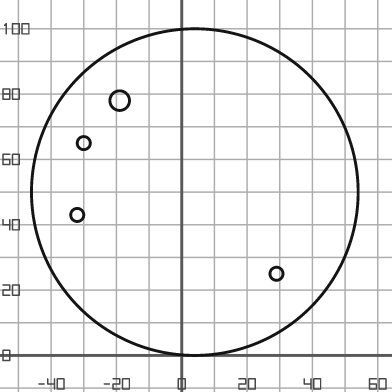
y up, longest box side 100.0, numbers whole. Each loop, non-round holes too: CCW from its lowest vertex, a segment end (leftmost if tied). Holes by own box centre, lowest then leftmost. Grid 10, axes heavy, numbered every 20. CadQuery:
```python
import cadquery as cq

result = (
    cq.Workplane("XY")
    .moveTo(4.0, 50.0)
    .circle(50.0)
    .moveTo(29.0, 25.0)
    .circle(2.0)
    .moveTo(-32.0, 43.0)
    .circle(2.0)
    .moveTo(-30.0, 65.0)
    .circle(2.0)
    .moveTo(-19.0, 78.0)
    .circle(3.0)
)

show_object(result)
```